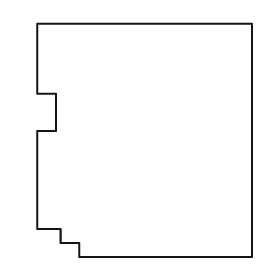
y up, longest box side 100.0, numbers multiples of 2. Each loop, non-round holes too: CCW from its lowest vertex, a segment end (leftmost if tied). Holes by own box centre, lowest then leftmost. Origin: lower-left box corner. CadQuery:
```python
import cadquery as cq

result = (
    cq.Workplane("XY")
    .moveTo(18.0, 0.0)
    .lineTo(92.0, 0.0)
    .lineTo(92.0, 100.0)
    .lineTo(0.0, 100.0)
    .lineTo(0.0, 70.0)
    .lineTo(8.0, 70.0)
    .lineTo(8.0, 54.0)
    .lineTo(0.0, 54.0)
    .lineTo(0.0, 12.0)
    .lineTo(10.0, 12.0)
    .lineTo(10.0, 6.0)
    .lineTo(18.0, 6.0)
    .close()
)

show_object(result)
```